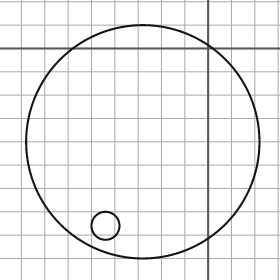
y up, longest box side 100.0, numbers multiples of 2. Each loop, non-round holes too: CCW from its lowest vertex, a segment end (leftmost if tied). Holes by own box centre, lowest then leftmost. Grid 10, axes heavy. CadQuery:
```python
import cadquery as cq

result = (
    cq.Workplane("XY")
    .moveTo(-28.0, -40.0)
    .circle(50.0)
    .moveTo(-44.0, -76.0)
    .circle(6.0)
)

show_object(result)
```